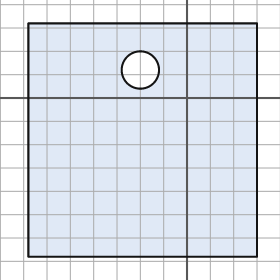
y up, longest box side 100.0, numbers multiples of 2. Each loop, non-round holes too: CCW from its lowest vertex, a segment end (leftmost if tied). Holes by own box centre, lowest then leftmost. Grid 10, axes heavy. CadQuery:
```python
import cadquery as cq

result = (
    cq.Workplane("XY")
    .moveTo(-68.0, -68.0)
    .lineTo(30.0, -68.0)
    .lineTo(30.0, 32.0)
    .lineTo(-68.0, 32.0)
    .close()
    .moveTo(-20.0, 12.0)
    .circle(8.0)
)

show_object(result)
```